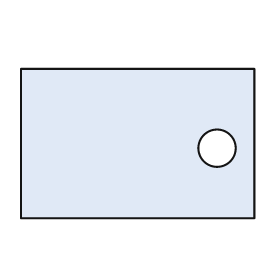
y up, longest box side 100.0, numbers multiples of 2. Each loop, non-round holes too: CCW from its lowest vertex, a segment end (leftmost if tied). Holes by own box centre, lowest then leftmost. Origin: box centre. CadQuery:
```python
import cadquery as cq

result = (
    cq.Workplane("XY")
    .moveTo(-50.0, -32.0)
    .lineTo(50.0, -32.0)
    .lineTo(50.0, 32.0)
    .lineTo(-50.0, 32.0)
    .close()
    .moveTo(34.0, -2.0)
    .circle(8.0)
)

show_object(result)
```